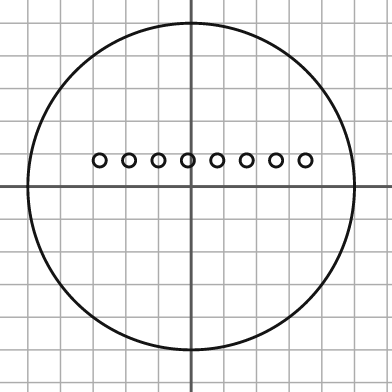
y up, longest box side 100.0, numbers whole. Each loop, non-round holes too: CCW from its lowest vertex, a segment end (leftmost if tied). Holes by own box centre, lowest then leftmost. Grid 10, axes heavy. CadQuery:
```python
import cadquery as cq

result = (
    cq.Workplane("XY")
    .moveTo(0.0, 0.0)
    .circle(50.0)
    .moveTo(-28.0, 8.0)
    .circle(2.0)
    .moveTo(-19.0, 8.0)
    .circle(2.0)
    .moveTo(-10.0, 8.0)
    .circle(2.0)
    .moveTo(-1.0, 8.0)
    .circle(2.0)
    .moveTo(8.0, 8.0)
    .circle(2.0)
    .moveTo(17.0, 8.0)
    .circle(2.0)
    .moveTo(26.0, 8.0)
    .circle(2.0)
    .moveTo(35.0, 8.0)
    .circle(2.0)
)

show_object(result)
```